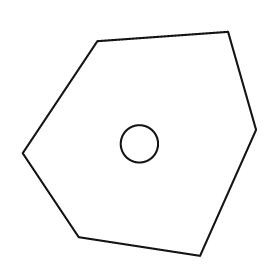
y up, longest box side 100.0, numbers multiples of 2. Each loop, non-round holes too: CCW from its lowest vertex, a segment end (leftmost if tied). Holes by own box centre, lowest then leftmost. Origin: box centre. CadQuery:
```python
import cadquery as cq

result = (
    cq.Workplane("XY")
    .moveTo(26.0, -48.0)
    .lineTo(50.0, 6.0)
    .lineTo(38.0, 48.0)
    .lineTo(-18.0, 44.0)
    .lineTo(-50.0, -4.0)
    .lineTo(-26.0, -40.0)
    .close()
    .moveTo(0.0, 0.0)
    .circle(8.0)
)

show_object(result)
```